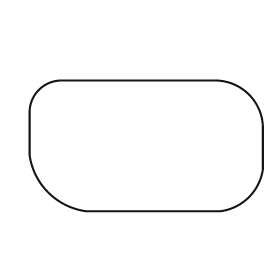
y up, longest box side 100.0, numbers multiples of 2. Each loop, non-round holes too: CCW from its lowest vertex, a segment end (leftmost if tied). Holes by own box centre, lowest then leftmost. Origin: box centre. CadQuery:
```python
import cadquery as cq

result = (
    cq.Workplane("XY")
    .moveTo(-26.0, -28.0)
    .lineTo(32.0, -28.0)
    .threePointArc((44.0, -22.0), (50.0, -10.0))
    .lineTo(50.0, 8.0)
    .threePointArc((44.0, 22.0), (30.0, 28.0))
    .lineTo(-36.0, 28.0)
    .threePointArc((-46.0, 24.0), (-50.0, 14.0))
    .lineTo(-50.0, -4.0)
    .threePointArc((-42.0, -20.0), (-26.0, -28.0))
    .close()
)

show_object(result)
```